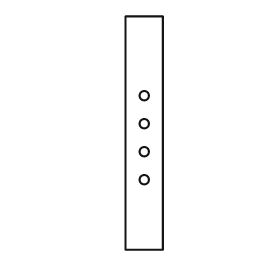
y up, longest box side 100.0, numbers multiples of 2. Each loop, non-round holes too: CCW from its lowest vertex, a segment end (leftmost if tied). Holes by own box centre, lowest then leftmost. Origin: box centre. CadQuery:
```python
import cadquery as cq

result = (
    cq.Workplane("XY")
    .moveTo(-8.0, -50.0)
    .lineTo(8.0, -50.0)
    .lineTo(8.0, 50.0)
    .lineTo(-8.0, 50.0)
    .close()
    .moveTo(0.0, -20.0)
    .circle(2.0)
    .moveTo(0.0, -8.0)
    .circle(2.0)
    .moveTo(0.0, 4.0)
    .circle(2.0)
    .moveTo(0.0, 16.0)
    .circle(2.0)
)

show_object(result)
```